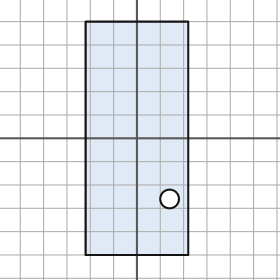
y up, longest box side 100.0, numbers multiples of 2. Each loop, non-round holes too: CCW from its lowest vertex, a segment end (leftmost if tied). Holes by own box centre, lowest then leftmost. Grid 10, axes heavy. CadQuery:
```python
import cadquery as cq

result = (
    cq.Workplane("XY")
    .moveTo(-22.0, -50.0)
    .lineTo(22.0, -50.0)
    .lineTo(22.0, 50.0)
    .lineTo(-22.0, 50.0)
    .close()
    .moveTo(14.0, -26.0)
    .circle(4.0)
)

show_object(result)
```